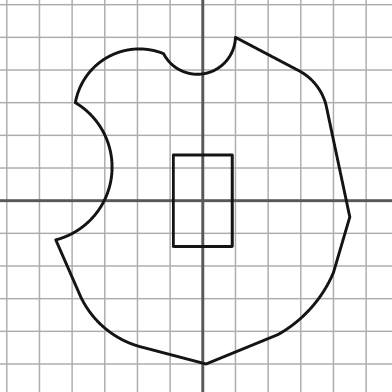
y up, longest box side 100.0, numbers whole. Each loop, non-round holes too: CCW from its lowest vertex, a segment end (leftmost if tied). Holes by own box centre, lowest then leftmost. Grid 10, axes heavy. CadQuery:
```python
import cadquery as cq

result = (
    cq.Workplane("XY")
    .moveTo(1.0, -50.0)
    .lineTo(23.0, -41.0)
    .threePointArc((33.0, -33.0), (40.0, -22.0))
    .lineTo(45.0, -5.0)
    .lineTo(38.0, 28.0)
    .threePointArc((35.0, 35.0), (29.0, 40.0))
    .lineTo(10.0, 50.0)
    .threePointArc((1.0, 39.0), (-12.0, 45.0))
    .threePointArc((-29.0, 44.0), (-39.0, 30.0))
    .threePointArc((-28.0, 7.0), (-45.0, -12.0))
    .lineTo(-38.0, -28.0)
    .threePointArc((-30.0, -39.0), (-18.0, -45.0))
    .close()
    .moveTo(-9.0, -14.0)
    .lineTo(9.0, -14.0)
    .lineTo(9.0, 14.0)
    .lineTo(-9.0, 14.0)
    .close()
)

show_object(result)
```